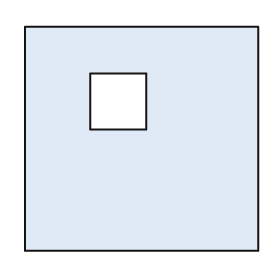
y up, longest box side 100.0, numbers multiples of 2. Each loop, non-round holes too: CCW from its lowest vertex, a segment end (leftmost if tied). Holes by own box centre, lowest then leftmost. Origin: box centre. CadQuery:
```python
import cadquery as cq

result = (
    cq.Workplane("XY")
    .moveTo(-50.0, -48.0)
    .lineTo(50.0, -48.0)
    .lineTo(50.0, 48.0)
    .lineTo(-50.0, 48.0)
    .close()
    .moveTo(-22.0, 4.0)
    .lineTo(2.0, 4.0)
    .lineTo(2.0, 28.0)
    .lineTo(-22.0, 28.0)
    .close()
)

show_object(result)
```